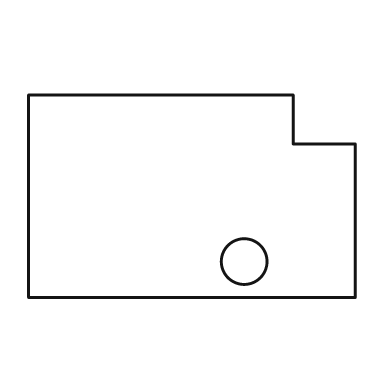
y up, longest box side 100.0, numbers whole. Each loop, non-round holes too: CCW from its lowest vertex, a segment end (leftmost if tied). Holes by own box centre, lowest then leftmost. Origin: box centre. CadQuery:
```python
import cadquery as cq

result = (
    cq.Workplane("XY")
    .moveTo(-50.0, -31.0)
    .lineTo(50.0, -31.0)
    .lineTo(50.0, 16.0)
    .lineTo(31.0, 16.0)
    .lineTo(31.0, 31.0)
    .lineTo(-50.0, 31.0)
    .close()
    .moveTo(16.0, -20.0)
    .circle(7.0)
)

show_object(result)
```